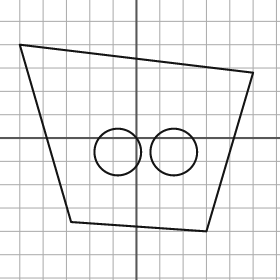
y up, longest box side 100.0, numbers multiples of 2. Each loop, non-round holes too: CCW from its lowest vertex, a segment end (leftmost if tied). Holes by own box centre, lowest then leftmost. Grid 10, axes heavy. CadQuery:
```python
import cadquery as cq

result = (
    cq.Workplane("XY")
    .moveTo(30.0, -40.0)
    .lineTo(50.0, 28.0)
    .lineTo(-50.0, 40.0)
    .lineTo(-28.0, -36.0)
    .close()
    .moveTo(-8.0, -6.0)
    .circle(10.0)
    .moveTo(16.0, -6.0)
    .circle(10.0)
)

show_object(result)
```